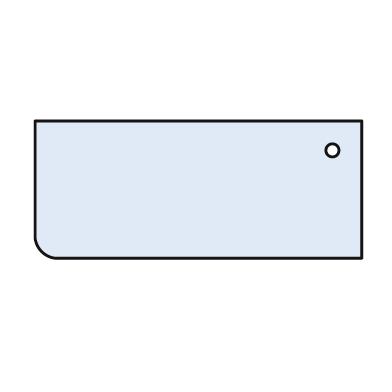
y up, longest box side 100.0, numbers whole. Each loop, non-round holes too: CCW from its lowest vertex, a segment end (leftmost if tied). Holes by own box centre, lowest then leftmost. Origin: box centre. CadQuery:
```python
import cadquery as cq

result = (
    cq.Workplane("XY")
    .moveTo(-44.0, -21.0)
    .lineTo(50.0, -21.0)
    .lineTo(50.0, 21.0)
    .lineTo(-50.0, 21.0)
    .lineTo(-50.0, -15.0)
    .threePointArc((-48.0, -19.0), (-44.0, -21.0))
    .close()
    .moveTo(41.0, 12.0)
    .circle(2.0)
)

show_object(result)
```